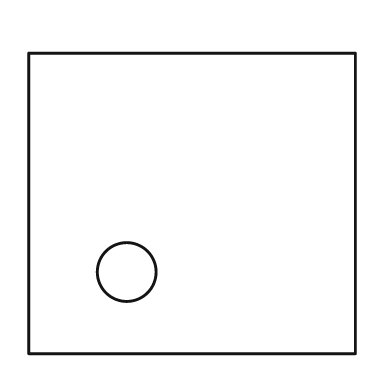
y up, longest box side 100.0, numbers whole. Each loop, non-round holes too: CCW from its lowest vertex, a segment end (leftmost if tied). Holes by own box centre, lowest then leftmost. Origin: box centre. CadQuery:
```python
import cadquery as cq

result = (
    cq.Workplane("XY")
    .moveTo(-50.0, -46.0)
    .lineTo(50.0, -46.0)
    .lineTo(50.0, 46.0)
    .lineTo(-50.0, 46.0)
    .close()
    .moveTo(-20.0, -21.0)
    .circle(9.0)
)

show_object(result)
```